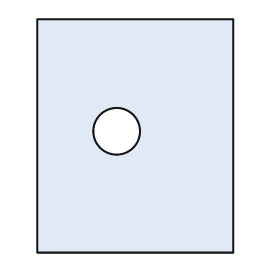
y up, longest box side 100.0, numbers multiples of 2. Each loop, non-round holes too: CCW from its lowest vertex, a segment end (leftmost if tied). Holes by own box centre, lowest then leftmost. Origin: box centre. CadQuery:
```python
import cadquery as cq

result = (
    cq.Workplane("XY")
    .moveTo(-42.0, -50.0)
    .lineTo(42.0, -50.0)
    .lineTo(42.0, 50.0)
    .lineTo(-42.0, 50.0)
    .close()
    .moveTo(-8.0, 2.0)
    .circle(10.0)
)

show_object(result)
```